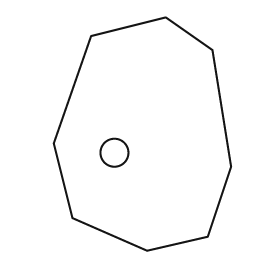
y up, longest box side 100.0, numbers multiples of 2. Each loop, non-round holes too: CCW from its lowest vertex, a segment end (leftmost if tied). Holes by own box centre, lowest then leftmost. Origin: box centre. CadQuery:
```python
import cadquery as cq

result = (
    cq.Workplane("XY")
    .moveTo(2.0, -50.0)
    .lineTo(28.0, -44.0)
    .lineTo(38.0, -14.0)
    .lineTo(30.0, 36.0)
    .lineTo(10.0, 50.0)
    .lineTo(-22.0, 42.0)
    .lineTo(-38.0, -4.0)
    .lineTo(-30.0, -36.0)
    .close()
    .moveTo(-12.0, -8.0)
    .circle(6.0)
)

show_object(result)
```